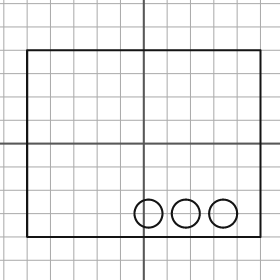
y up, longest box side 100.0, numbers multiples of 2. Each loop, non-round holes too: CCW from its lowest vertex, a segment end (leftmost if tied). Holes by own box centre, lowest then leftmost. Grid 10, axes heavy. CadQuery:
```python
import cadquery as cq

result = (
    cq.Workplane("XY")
    .moveTo(-50.0, -40.0)
    .lineTo(50.0, -40.0)
    .lineTo(50.0, 40.0)
    .lineTo(-50.0, 40.0)
    .close()
    .moveTo(2.0, -30.0)
    .circle(6.0)
    .moveTo(18.0, -30.0)
    .circle(6.0)
    .moveTo(34.0, -30.0)
    .circle(6.0)
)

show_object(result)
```